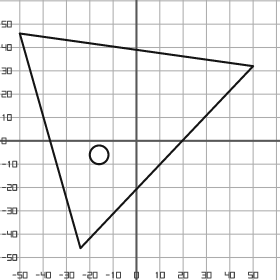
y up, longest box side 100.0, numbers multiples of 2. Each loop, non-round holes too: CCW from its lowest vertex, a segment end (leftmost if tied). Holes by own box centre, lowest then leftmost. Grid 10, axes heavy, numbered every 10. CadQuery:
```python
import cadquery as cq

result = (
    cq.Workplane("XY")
    .moveTo(-24.0, -46.0)
    .lineTo(50.0, 32.0)
    .lineTo(-50.0, 46.0)
    .close()
    .moveTo(-16.0, -6.0)
    .circle(4.0)
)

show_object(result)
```